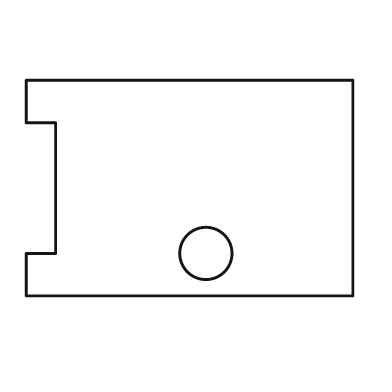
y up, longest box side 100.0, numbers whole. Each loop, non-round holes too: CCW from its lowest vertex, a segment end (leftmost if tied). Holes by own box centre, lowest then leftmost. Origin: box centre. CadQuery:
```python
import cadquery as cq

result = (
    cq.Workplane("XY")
    .moveTo(-50.0, -33.0)
    .lineTo(50.0, -33.0)
    .lineTo(50.0, 33.0)
    .lineTo(-50.0, 33.0)
    .lineTo(-50.0, 20.0)
    .lineTo(-41.0, 20.0)
    .lineTo(-41.0, -20.0)
    .lineTo(-50.0, -20.0)
    .close()
    .moveTo(5.0, -20.0)
    .circle(8.0)
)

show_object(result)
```